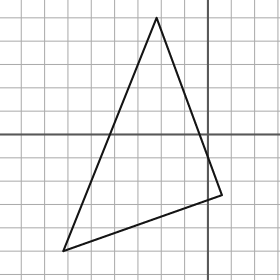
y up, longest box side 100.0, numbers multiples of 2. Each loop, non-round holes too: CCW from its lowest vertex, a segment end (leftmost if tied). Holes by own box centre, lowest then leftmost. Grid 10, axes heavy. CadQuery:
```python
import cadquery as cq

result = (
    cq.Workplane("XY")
    .moveTo(-62.0, -50.0)
    .lineTo(6.0, -26.0)
    .lineTo(-22.0, 50.0)
    .close()
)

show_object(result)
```